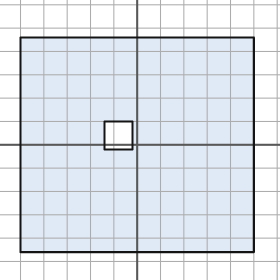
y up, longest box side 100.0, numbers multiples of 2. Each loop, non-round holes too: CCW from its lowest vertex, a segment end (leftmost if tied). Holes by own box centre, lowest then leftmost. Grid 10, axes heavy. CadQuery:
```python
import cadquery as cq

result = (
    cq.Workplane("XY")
    .moveTo(-50.0, -46.0)
    .lineTo(50.0, -46.0)
    .lineTo(50.0, 46.0)
    .lineTo(-50.0, 46.0)
    .close()
    .moveTo(-14.0, -2.0)
    .lineTo(-2.0, -2.0)
    .lineTo(-2.0, 10.0)
    .lineTo(-14.0, 10.0)
    .close()
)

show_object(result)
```